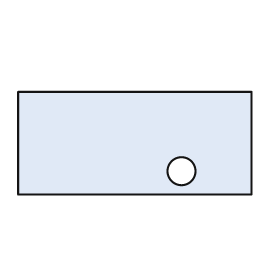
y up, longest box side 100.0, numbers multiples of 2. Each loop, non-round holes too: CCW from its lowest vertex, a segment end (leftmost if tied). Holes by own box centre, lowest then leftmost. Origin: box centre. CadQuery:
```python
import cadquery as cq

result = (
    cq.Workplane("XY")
    .moveTo(-50.0, -22.0)
    .lineTo(50.0, -22.0)
    .lineTo(50.0, 22.0)
    .lineTo(-50.0, 22.0)
    .close()
    .moveTo(20.0, -12.0)
    .circle(6.0)
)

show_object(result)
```